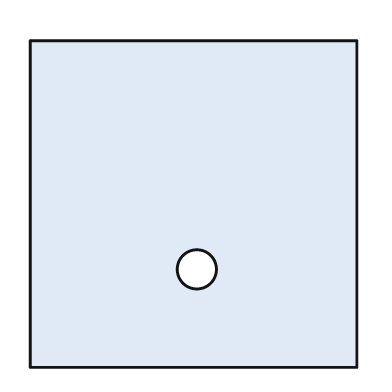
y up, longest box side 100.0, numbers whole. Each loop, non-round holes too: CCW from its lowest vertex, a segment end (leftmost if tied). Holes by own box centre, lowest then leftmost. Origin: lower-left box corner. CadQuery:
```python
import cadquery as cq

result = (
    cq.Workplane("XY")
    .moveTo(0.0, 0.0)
    .lineTo(100.0, 0.0)
    .lineTo(100.0, 100.0)
    .lineTo(0.0, 100.0)
    .close()
    .moveTo(51.0, 30.0)
    .circle(6.0)
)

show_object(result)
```